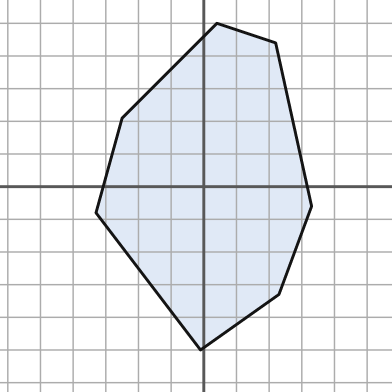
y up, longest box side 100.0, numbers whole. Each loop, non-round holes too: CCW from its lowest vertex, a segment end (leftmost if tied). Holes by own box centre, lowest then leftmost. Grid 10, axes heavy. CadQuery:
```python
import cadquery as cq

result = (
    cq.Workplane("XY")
    .moveTo(-1.0, -50.0)
    .lineTo(23.0, -33.0)
    .lineTo(33.0, -6.0)
    .lineTo(22.0, 44.0)
    .lineTo(4.0, 50.0)
    .lineTo(-25.0, 21.0)
    .lineTo(-33.0, -8.0)
    .close()
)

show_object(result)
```